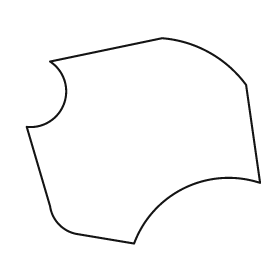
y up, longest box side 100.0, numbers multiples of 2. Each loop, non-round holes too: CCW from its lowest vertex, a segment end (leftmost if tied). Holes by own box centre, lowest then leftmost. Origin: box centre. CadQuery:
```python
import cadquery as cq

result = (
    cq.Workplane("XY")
    .moveTo(-4.0, -44.0)
    .threePointArc((18.0, -20.0), (50.0, -18.0))
    .lineTo(44.0, 24.0)
    .threePointArc((28.0, 38.0), (8.0, 44.0))
    .lineTo(-40.0, 34.0)
    .threePointArc((-34.0, 16.0), (-50.0, 6.0))
    .lineTo(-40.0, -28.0)
    .threePointArc((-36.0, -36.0), (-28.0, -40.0))
    .close()
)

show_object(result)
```